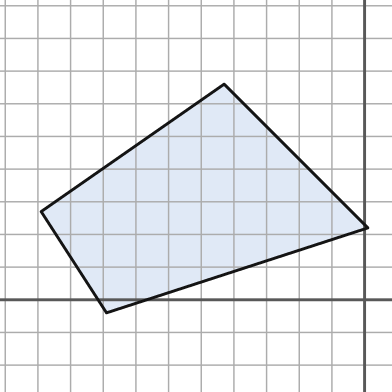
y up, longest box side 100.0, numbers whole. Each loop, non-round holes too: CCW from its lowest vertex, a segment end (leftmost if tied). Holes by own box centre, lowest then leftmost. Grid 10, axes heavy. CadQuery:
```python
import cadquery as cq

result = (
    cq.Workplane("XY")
    .moveTo(-79.0, -4.0)
    .lineTo(1.0, 22.0)
    .lineTo(-43.0, 66.0)
    .lineTo(-99.0, 27.0)
    .close()
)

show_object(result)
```